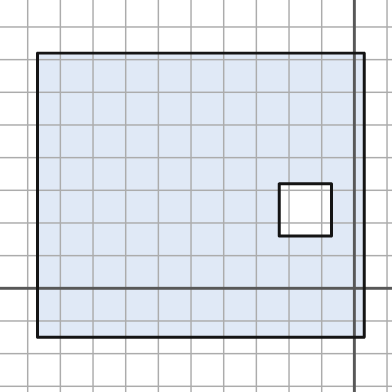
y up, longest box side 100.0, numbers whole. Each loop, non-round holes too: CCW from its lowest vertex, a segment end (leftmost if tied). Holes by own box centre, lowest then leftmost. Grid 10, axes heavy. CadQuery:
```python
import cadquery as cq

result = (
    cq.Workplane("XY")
    .moveTo(-97.0, -15.0)
    .lineTo(3.0, -15.0)
    .lineTo(3.0, 72.0)
    .lineTo(-97.0, 72.0)
    .close()
    .moveTo(-23.0, 16.0)
    .lineTo(-7.0, 16.0)
    .lineTo(-7.0, 32.0)
    .lineTo(-23.0, 32.0)
    .close()
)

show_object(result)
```